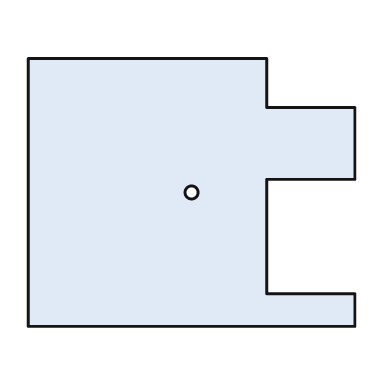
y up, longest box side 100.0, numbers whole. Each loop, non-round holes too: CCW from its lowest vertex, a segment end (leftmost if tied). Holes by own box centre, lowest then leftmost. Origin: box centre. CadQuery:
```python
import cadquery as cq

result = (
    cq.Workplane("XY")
    .moveTo(-50.0, -41.0)
    .lineTo(50.0, -41.0)
    .lineTo(50.0, -31.0)
    .lineTo(23.0, -31.0)
    .lineTo(23.0, 4.0)
    .lineTo(50.0, 4.0)
    .lineTo(50.0, 26.0)
    .lineTo(23.0, 26.0)
    .lineTo(23.0, 41.0)
    .lineTo(-50.0, 41.0)
    .close()
    .moveTo(0.0, 0.0)
    .circle(2.0)
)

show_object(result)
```